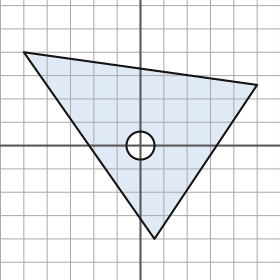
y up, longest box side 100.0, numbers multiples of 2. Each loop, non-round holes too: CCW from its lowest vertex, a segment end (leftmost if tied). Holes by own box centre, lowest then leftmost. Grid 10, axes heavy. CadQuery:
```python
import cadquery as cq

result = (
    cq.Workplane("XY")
    .moveTo(6.0, -40.0)
    .lineTo(50.0, 26.0)
    .lineTo(-50.0, 40.0)
    .close()
    .moveTo(0.0, 0.0)
    .circle(6.0)
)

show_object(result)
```